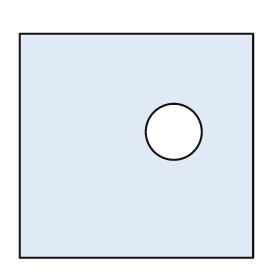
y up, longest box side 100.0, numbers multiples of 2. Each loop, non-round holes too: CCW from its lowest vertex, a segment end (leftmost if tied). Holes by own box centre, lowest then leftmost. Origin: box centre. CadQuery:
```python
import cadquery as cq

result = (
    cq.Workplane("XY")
    .moveTo(-50.0, -48.0)
    .lineTo(50.0, -48.0)
    .lineTo(50.0, 48.0)
    .lineTo(-50.0, 48.0)
    .close()
    .moveTo(16.0, 6.0)
    .circle(12.0)
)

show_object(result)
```